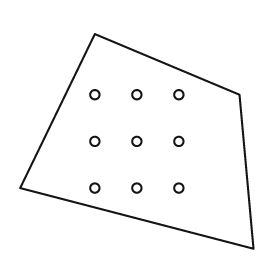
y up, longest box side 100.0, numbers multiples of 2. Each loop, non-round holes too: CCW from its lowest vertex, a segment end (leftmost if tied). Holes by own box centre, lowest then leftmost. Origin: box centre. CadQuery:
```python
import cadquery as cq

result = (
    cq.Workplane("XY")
    .moveTo(50.0, -46.0)
    .lineTo(44.0, 20.0)
    .lineTo(-18.0, 46.0)
    .lineTo(-50.0, -20.0)
    .close()
    .moveTo(-18.0, -20.0)
    .circle(2.0)
    .moveTo(0.0, -20.0)
    .circle(2.0)
    .moveTo(18.0, -20.0)
    .circle(2.0)
    .moveTo(-18.0, 0.0)
    .circle(2.0)
    .moveTo(0.0, 0.0)
    .circle(2.0)
    .moveTo(18.0, 0.0)
    .circle(2.0)
    .moveTo(-18.0, 20.0)
    .circle(2.0)
    .moveTo(0.0, 20.0)
    .circle(2.0)
    .moveTo(18.0, 20.0)
    .circle(2.0)
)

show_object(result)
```